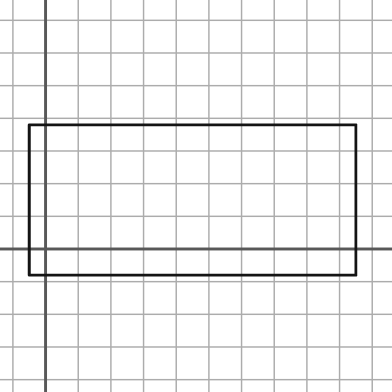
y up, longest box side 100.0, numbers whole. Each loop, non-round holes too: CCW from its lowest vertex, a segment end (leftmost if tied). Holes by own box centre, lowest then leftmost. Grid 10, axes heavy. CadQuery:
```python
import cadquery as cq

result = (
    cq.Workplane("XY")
    .moveTo(-5.0, -8.0)
    .lineTo(95.0, -8.0)
    .lineTo(95.0, 38.0)
    .lineTo(-5.0, 38.0)
    .close()
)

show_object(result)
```